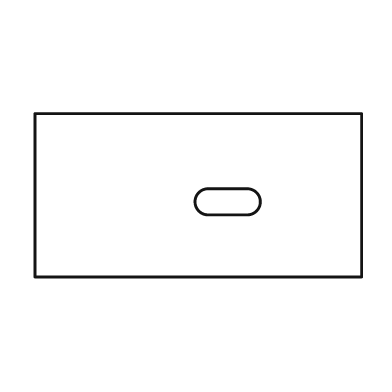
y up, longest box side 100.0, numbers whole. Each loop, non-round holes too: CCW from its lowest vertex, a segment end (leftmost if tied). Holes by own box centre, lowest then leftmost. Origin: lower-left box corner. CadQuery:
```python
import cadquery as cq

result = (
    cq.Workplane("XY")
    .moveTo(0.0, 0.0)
    .lineTo(100.0, 0.0)
    .lineTo(100.0, 50.0)
    .lineTo(0.0, 50.0)
    .close()
    .moveTo(53.0, 19.0)
    .lineTo(65.0, 19.0)
    .threePointArc((69.0, 23.0), (65.0, 27.0))
    .lineTo(53.0, 27.0)
    .threePointArc((49.0, 23.0), (53.0, 19.0))
    .close()
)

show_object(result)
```